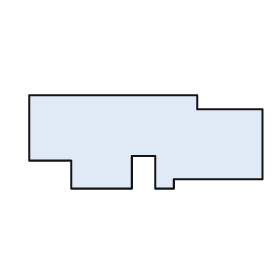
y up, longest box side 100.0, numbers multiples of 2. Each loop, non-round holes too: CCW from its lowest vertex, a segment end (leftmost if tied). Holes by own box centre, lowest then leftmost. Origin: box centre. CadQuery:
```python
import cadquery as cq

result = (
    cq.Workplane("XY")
    .moveTo(-32.0, -20.0)
    .lineTo(-6.0, -20.0)
    .lineTo(-6.0, -6.0)
    .lineTo(4.0, -6.0)
    .lineTo(4.0, -20.0)
    .lineTo(12.0, -20.0)
    .lineTo(12.0, -16.0)
    .lineTo(50.0, -16.0)
    .lineTo(50.0, 14.0)
    .lineTo(22.0, 14.0)
    .lineTo(22.0, 20.0)
    .lineTo(-50.0, 20.0)
    .lineTo(-50.0, -8.0)
    .lineTo(-32.0, -8.0)
    .close()
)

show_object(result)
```